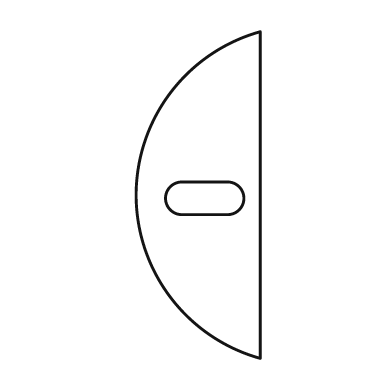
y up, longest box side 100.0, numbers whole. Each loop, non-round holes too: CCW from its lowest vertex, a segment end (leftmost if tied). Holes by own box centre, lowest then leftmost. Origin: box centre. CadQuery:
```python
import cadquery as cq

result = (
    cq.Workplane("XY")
    .moveTo(19.0, -50.0)
    .lineTo(19.0, 50.0)
    .threePointArc((-19.0, 0.0), (19.0, -50.0))
    .close()
    .moveTo(-5.0, -6.0)
    .lineTo(9.0, -6.0)
    .threePointArc((14.0, -1.0), (9.0, 4.0))
    .lineTo(-5.0, 4.0)
    .threePointArc((-10.0, -1.0), (-5.0, -6.0))
    .close()
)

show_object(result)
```